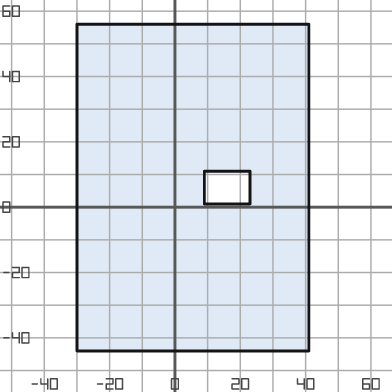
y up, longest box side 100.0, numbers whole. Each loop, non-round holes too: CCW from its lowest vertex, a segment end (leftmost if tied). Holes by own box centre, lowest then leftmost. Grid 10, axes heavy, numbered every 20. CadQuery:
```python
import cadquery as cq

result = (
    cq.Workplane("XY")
    .moveTo(-30.0, -44.0)
    .lineTo(41.0, -44.0)
    .lineTo(41.0, 56.0)
    .lineTo(-30.0, 56.0)
    .close()
    .moveTo(9.0, 1.0)
    .lineTo(23.0, 1.0)
    .lineTo(23.0, 11.0)
    .lineTo(9.0, 11.0)
    .close()
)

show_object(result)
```